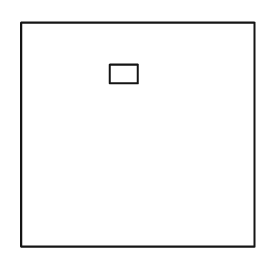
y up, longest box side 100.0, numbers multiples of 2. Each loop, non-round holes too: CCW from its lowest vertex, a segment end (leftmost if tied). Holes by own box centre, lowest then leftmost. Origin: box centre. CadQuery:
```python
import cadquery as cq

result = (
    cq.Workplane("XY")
    .moveTo(-50.0, -48.0)
    .lineTo(50.0, -48.0)
    .lineTo(50.0, 48.0)
    .lineTo(-50.0, 48.0)
    .close()
    .moveTo(-12.0, 22.0)
    .lineTo(0.0, 22.0)
    .lineTo(0.0, 30.0)
    .lineTo(-12.0, 30.0)
    .close()
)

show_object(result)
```